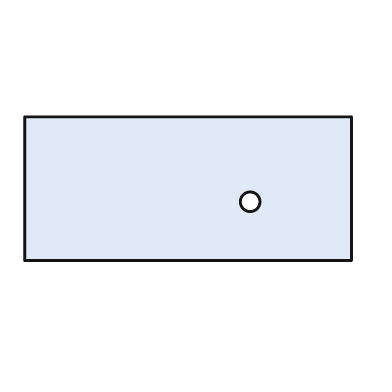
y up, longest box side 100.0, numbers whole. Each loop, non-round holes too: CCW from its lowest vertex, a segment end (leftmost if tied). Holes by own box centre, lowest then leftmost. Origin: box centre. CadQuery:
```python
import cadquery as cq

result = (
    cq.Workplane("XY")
    .moveTo(-50.0, -22.0)
    .lineTo(50.0, -22.0)
    .lineTo(50.0, 22.0)
    .lineTo(-50.0, 22.0)
    .close()
    .moveTo(19.0, -4.0)
    .circle(3.0)
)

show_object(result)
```